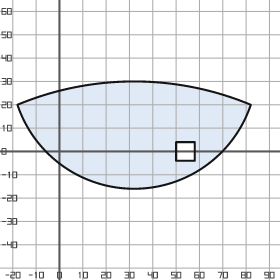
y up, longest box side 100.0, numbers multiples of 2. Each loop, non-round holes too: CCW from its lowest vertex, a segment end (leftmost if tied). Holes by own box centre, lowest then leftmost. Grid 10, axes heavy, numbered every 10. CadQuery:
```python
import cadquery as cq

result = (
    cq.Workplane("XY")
    .moveTo(-18.0, 20.0)
    .threePointArc((32.0, -16.0), (82.0, 20.0))
    .threePointArc((32.0, 30.0), (-18.0, 20.0))
    .close()
    .moveTo(50.0, -4.0)
    .lineTo(58.0, -4.0)
    .lineTo(58.0, 4.0)
    .lineTo(50.0, 4.0)
    .close()
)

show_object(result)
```